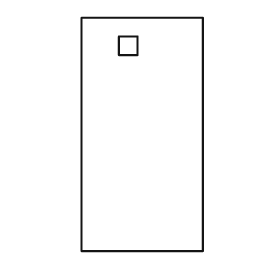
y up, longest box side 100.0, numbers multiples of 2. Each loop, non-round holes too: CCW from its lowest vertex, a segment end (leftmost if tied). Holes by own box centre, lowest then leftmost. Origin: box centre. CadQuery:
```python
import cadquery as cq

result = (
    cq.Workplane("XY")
    .moveTo(-26.0, -50.0)
    .lineTo(26.0, -50.0)
    .lineTo(26.0, 50.0)
    .lineTo(-26.0, 50.0)
    .close()
    .moveTo(-10.0, 34.0)
    .lineTo(-2.0, 34.0)
    .lineTo(-2.0, 42.0)
    .lineTo(-10.0, 42.0)
    .close()
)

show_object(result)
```